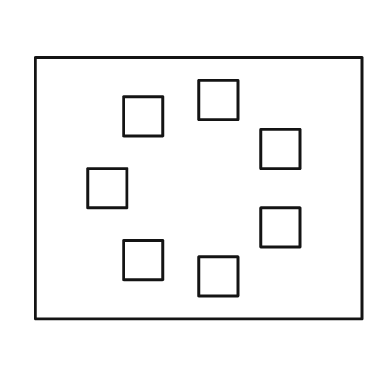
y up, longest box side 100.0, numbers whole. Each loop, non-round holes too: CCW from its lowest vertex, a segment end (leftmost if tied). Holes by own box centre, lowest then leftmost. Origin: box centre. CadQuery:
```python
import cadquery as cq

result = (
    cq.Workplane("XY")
    .moveTo(-50.0, -40.0)
    .lineTo(50.0, -40.0)
    .lineTo(50.0, 40.0)
    .lineTo(-50.0, 40.0)
    .close()
    .moveTo(0.0, -33.0)
    .lineTo(12.0, -33.0)
    .lineTo(12.0, -21.0)
    .lineTo(0.0, -21.0)
    .close()
    .moveTo(-23.0, -28.0)
    .lineTo(-11.0, -28.0)
    .lineTo(-11.0, -16.0)
    .lineTo(-23.0, -16.0)
    .close()
    .moveTo(19.0, -18.0)
    .lineTo(31.0, -18.0)
    .lineTo(31.0, -6.0)
    .lineTo(19.0, -6.0)
    .close()
    .moveTo(-34.0, -6.0)
    .lineTo(-22.0, -6.0)
    .lineTo(-22.0, 6.0)
    .lineTo(-34.0, 6.0)
    .close()
    .moveTo(19.0, 6.0)
    .lineTo(31.0, 6.0)
    .lineTo(31.0, 18.0)
    .lineTo(19.0, 18.0)
    .close()
    .moveTo(-23.0, 16.0)
    .lineTo(-11.0, 16.0)
    .lineTo(-11.0, 28.0)
    .lineTo(-23.0, 28.0)
    .close()
    .moveTo(0.0, 21.0)
    .lineTo(12.0, 21.0)
    .lineTo(12.0, 33.0)
    .lineTo(0.0, 33.0)
    .close()
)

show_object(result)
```